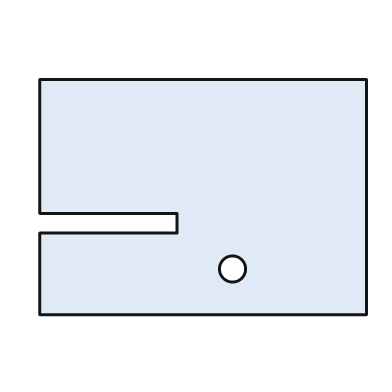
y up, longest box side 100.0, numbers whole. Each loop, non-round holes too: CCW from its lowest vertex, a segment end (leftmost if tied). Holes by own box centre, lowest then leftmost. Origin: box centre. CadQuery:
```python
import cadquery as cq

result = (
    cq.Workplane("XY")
    .moveTo(-50.0, -36.0)
    .lineTo(50.0, -36.0)
    .lineTo(50.0, 36.0)
    .lineTo(-50.0, 36.0)
    .lineTo(-50.0, -5.0)
    .lineTo(-8.0, -5.0)
    .lineTo(-8.0, -11.0)
    .lineTo(-50.0, -11.0)
    .close()
    .moveTo(9.0, -22.0)
    .circle(4.0)
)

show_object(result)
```